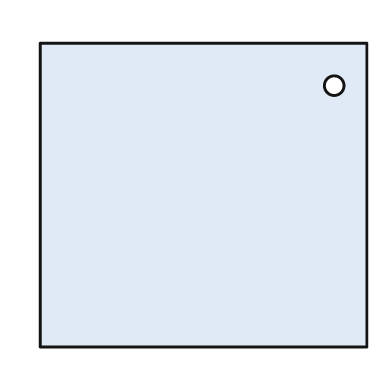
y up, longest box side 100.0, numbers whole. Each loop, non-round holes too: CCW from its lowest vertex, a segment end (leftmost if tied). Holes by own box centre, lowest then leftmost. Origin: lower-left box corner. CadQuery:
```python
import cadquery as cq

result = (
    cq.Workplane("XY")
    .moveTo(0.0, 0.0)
    .lineTo(100.0, 0.0)
    .lineTo(100.0, 93.0)
    .lineTo(0.0, 93.0)
    .close()
    .moveTo(90.0, 80.0)
    .circle(3.0)
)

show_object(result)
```